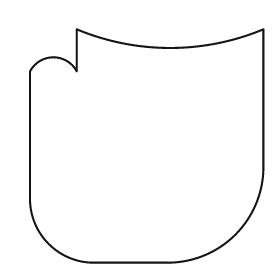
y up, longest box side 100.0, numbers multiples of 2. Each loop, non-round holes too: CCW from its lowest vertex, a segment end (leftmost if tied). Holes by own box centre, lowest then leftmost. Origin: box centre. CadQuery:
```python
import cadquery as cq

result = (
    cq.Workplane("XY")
    .moveTo(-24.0, -50.0)
    .lineTo(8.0, -50.0)
    .threePointArc((38.0, -38.0), (50.0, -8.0))
    .lineTo(50.0, 50.0)
    .threePointArc((10.0, 42.0), (-30.0, 50.0))
    .lineTo(-30.0, 32.0)
    .threePointArc((-40.0, 38.0), (-50.0, 32.0))
    .lineTo(-50.0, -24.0)
    .threePointArc((-42.0, -42.0), (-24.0, -50.0))
    .close()
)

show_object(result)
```